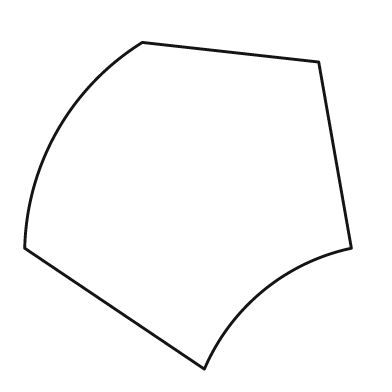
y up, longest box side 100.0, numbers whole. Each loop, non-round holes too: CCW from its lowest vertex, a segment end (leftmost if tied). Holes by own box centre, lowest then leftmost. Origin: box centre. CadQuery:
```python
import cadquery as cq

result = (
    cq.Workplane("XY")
    .moveTo(5.0, -50.0)
    .threePointArc((23.0, -26.0), (50.0, -13.0))
    .lineTo(40.0, 44.0)
    .lineTo(-14.0, 50.0)
    .threePointArc((-40.0, 23.0), (-50.0, -13.0))
    .close()
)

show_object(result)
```